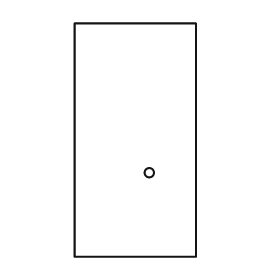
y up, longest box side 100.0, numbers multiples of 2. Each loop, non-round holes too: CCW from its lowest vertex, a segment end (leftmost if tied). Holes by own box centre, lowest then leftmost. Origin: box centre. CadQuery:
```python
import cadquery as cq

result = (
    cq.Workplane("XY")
    .moveTo(-26.0, -50.0)
    .lineTo(26.0, -50.0)
    .lineTo(26.0, 50.0)
    .lineTo(-26.0, 50.0)
    .close()
    .moveTo(6.0, -14.0)
    .circle(2.0)
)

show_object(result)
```